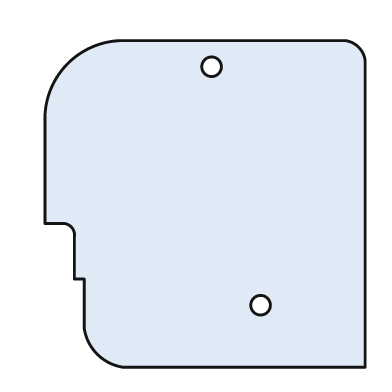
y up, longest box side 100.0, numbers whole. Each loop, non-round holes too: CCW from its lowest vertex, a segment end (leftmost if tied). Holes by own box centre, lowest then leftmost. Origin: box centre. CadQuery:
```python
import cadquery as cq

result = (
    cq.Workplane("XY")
    .moveTo(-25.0, -50.0)
    .lineTo(49.0, -50.0)
    .lineTo(49.0, 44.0)
    .threePointArc((47.0, 48.0), (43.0, 50.0))
    .lineTo(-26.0, 50.0)
    .threePointArc((-42.0, 43.0), (-49.0, 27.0))
    .lineTo(-49.0, -6.0)
    .lineTo(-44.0, -6.0)
    .threePointArc((-41.0, -7.0), (-40.0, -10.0))
    .lineTo(-40.0, -23.0)
    .lineTo(-37.0, -23.0)
    .lineTo(-37.0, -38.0)
    .threePointArc((-33.0, -46.0), (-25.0, -50.0))
    .close()
    .moveTo(17.0, -31.0)
    .circle(3.0)
    .moveTo(2.0, 42.0)
    .circle(3.0)
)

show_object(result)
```